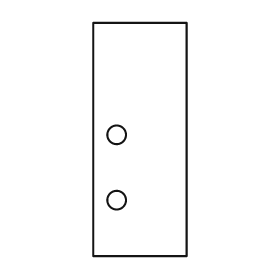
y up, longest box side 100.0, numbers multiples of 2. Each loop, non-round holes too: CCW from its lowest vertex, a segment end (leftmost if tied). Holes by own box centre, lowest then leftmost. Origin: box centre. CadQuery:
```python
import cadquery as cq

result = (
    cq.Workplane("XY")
    .moveTo(-20.0, -50.0)
    .lineTo(20.0, -50.0)
    .lineTo(20.0, 50.0)
    .lineTo(-20.0, 50.0)
    .close()
    .moveTo(-10.0, -26.0)
    .circle(4.0)
    .moveTo(-10.0, 2.0)
    .circle(4.0)
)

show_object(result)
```